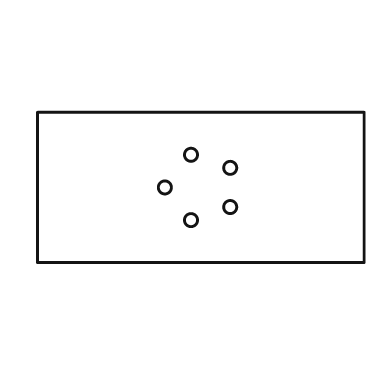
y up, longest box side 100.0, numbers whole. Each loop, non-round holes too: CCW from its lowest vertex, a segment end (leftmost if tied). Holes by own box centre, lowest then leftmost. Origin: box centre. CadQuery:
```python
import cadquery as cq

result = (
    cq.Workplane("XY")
    .moveTo(-50.0, -23.0)
    .lineTo(50.0, -23.0)
    .lineTo(50.0, 23.0)
    .lineTo(-50.0, 23.0)
    .close()
    .moveTo(-3.0, -10.0)
    .circle(2.0)
    .moveTo(9.0, -6.0)
    .circle(2.0)
    .moveTo(-11.0, 0.0)
    .circle(2.0)
    .moveTo(9.0, 6.0)
    .circle(2.0)
    .moveTo(-3.0, 10.0)
    .circle(2.0)
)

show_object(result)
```